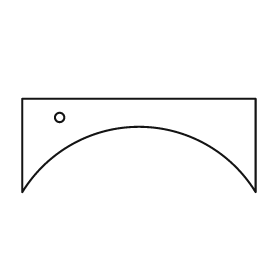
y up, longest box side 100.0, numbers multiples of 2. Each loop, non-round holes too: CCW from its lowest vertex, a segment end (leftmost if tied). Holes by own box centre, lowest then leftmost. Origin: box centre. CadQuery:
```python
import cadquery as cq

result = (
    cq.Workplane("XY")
    .moveTo(-50.0, -20.0)
    .threePointArc((0.0, 8.0), (50.0, -20.0))
    .lineTo(50.0, 20.0)
    .lineTo(-50.0, 20.0)
    .close()
    .moveTo(-34.0, 12.0)
    .circle(2.0)
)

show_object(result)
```